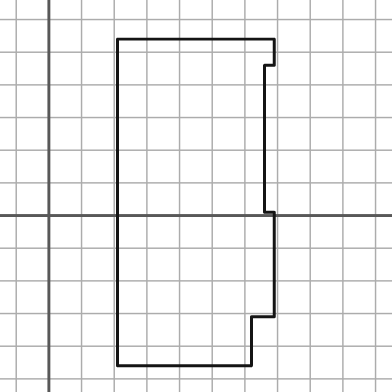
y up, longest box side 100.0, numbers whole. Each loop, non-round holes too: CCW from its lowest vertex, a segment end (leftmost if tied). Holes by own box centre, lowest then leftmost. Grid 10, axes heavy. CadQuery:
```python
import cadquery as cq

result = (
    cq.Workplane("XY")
    .moveTo(21.0, -46.0)
    .lineTo(62.0, -46.0)
    .lineTo(62.0, -31.0)
    .lineTo(69.0, -31.0)
    .lineTo(69.0, 1.0)
    .lineTo(66.0, 1.0)
    .lineTo(66.0, 46.0)
    .lineTo(69.0, 46.0)
    .lineTo(69.0, 54.0)
    .lineTo(21.0, 54.0)
    .close()
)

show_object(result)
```